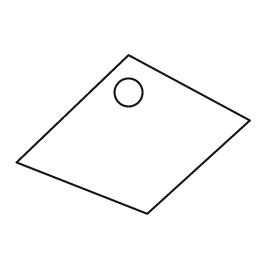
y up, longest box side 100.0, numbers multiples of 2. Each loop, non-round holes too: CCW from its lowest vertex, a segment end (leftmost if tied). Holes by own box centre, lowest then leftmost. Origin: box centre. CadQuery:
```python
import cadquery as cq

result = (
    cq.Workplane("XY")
    .moveTo(6.0, -34.0)
    .lineTo(50.0, 6.0)
    .lineTo(-2.0, 34.0)
    .lineTo(-50.0, -12.0)
    .close()
    .moveTo(-2.0, 18.0)
    .circle(6.0)
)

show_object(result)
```